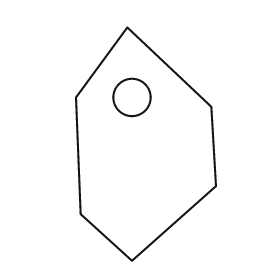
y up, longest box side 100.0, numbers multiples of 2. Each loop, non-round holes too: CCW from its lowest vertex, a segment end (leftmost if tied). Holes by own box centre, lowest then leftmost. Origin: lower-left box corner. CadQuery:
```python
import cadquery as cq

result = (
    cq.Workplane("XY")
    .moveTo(24.0, 0.0)
    .lineTo(60.0, 32.0)
    .lineTo(58.0, 66.0)
    .lineTo(22.0, 100.0)
    .lineTo(0.0, 70.0)
    .lineTo(2.0, 20.0)
    .close()
    .moveTo(24.0, 70.0)
    .circle(8.0)
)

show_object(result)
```